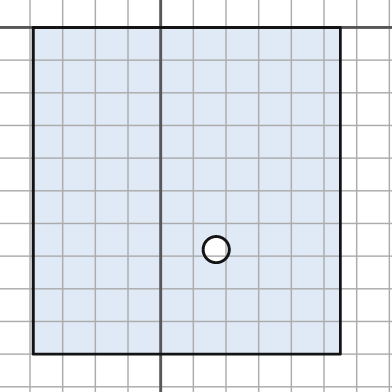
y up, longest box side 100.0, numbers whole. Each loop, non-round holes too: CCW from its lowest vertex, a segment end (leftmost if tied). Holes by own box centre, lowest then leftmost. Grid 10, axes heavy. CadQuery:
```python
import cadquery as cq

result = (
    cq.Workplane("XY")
    .moveTo(-39.0, -100.0)
    .lineTo(55.0, -100.0)
    .lineTo(55.0, 0.0)
    .lineTo(-39.0, 0.0)
    .close()
    .moveTo(17.0, -68.0)
    .circle(4.0)
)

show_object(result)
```